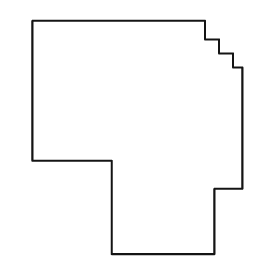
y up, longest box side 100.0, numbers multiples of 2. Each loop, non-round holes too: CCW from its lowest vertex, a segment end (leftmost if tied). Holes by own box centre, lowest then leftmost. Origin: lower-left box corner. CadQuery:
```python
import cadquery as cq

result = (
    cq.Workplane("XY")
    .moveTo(34.0, 0.0)
    .lineTo(78.0, 0.0)
    .lineTo(78.0, 28.0)
    .lineTo(90.0, 28.0)
    .lineTo(90.0, 80.0)
    .lineTo(86.0, 80.0)
    .lineTo(86.0, 86.0)
    .lineTo(80.0, 86.0)
    .lineTo(80.0, 92.0)
    .lineTo(74.0, 92.0)
    .lineTo(74.0, 100.0)
    .lineTo(0.0, 100.0)
    .lineTo(0.0, 40.0)
    .lineTo(34.0, 40.0)
    .close()
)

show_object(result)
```